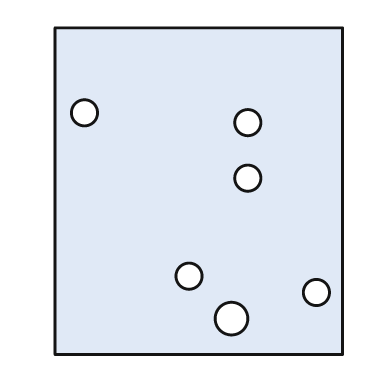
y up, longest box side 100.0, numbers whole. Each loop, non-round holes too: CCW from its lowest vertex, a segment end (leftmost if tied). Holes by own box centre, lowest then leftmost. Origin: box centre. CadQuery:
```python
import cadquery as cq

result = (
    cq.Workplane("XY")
    .moveTo(-44.0, -50.0)
    .lineTo(44.0, -50.0)
    .lineTo(44.0, 50.0)
    .lineTo(-44.0, 50.0)
    .close()
    .moveTo(10.0, -39.0)
    .circle(5.0)
    .moveTo(36.0, -31.0)
    .circle(4.0)
    .moveTo(-3.0, -26.0)
    .circle(4.0)
    .moveTo(15.0, 4.0)
    .circle(4.0)
    .moveTo(15.0, 21.0)
    .circle(4.0)
    .moveTo(-35.0, 24.0)
    .circle(4.0)
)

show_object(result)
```